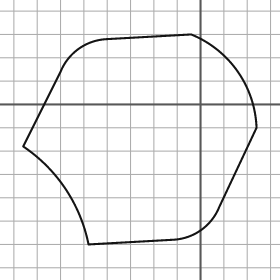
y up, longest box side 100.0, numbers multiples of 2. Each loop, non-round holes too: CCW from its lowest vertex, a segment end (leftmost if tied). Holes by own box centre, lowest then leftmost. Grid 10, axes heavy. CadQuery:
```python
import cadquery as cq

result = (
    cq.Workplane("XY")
    .moveTo(-48.0, -60.0)
    .lineTo(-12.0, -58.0)
    .threePointArc((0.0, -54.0), (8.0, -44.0))
    .lineTo(24.0, -10.0)
    .threePointArc((16.0, 14.0), (-4.0, 30.0))
    .lineTo(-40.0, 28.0)
    .threePointArc((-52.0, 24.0), (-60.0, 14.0))
    .lineTo(-76.0, -18.0)
    .threePointArc((-58.0, -36.0), (-48.0, -60.0))
    .close()
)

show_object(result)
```